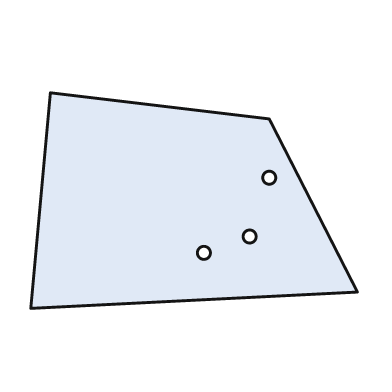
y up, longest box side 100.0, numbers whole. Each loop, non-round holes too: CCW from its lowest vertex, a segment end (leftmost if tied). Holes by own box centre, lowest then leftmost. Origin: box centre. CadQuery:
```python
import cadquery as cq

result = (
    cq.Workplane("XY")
    .moveTo(-50.0, -33.0)
    .lineTo(50.0, -28.0)
    .lineTo(23.0, 25.0)
    .lineTo(-44.0, 33.0)
    .close()
    .moveTo(3.0, -16.0)
    .circle(2.0)
    .moveTo(17.0, -11.0)
    .circle(2.0)
    .moveTo(23.0, 7.0)
    .circle(2.0)
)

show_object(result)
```